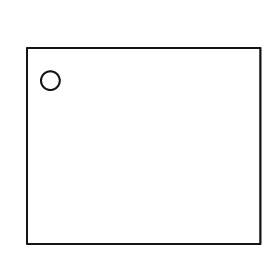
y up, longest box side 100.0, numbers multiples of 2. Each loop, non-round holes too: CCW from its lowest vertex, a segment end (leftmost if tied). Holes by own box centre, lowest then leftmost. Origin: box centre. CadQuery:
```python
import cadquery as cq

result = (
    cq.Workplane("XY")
    .moveTo(-50.0, -42.0)
    .lineTo(50.0, -42.0)
    .lineTo(50.0, 42.0)
    .lineTo(-50.0, 42.0)
    .close()
    .moveTo(-40.0, 28.0)
    .circle(4.0)
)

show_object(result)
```